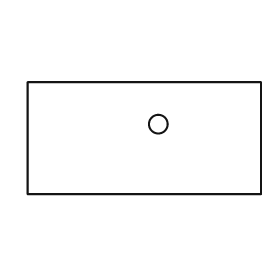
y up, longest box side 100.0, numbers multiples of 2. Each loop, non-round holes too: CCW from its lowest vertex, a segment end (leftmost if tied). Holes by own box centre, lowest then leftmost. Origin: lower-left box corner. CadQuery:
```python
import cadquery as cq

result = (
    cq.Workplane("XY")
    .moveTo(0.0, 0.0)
    .lineTo(100.0, 0.0)
    .lineTo(100.0, 48.0)
    .lineTo(0.0, 48.0)
    .close()
    .moveTo(56.0, 30.0)
    .circle(4.0)
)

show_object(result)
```